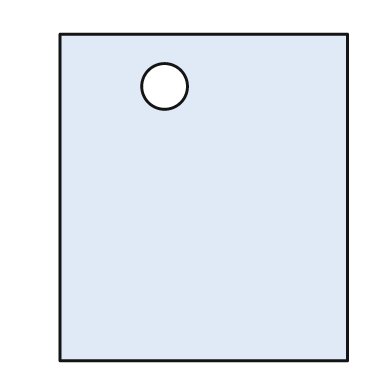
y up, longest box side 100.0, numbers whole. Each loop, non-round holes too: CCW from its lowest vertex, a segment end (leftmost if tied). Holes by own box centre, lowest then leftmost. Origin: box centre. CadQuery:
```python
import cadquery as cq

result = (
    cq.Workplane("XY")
    .moveTo(-44.0, -50.0)
    .lineTo(44.0, -50.0)
    .lineTo(44.0, 50.0)
    .lineTo(-44.0, 50.0)
    .close()
    .moveTo(-12.0, 34.0)
    .circle(7.0)
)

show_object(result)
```